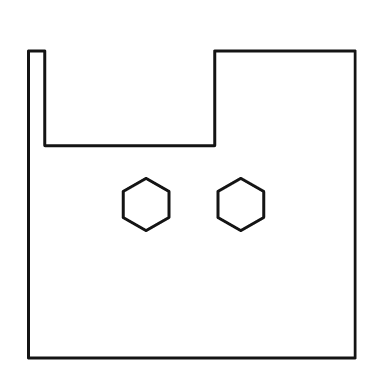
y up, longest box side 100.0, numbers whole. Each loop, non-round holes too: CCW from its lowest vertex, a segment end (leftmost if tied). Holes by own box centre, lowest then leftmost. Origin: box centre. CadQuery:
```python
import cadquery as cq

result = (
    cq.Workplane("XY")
    .moveTo(-50.0, -47.0)
    .lineTo(50.0, -47.0)
    .lineTo(50.0, 47.0)
    .lineTo(7.0, 47.0)
    .lineTo(7.0, 18.0)
    .lineTo(-45.0, 18.0)
    .lineTo(-45.0, 47.0)
    .lineTo(-50.0, 47.0)
    .close()
    .moveTo(-14.0, -8.0)
    .lineTo(-7.0, -4.0)
    .lineTo(-7.0, 4.0)
    .lineTo(-14.0, 8.0)
    .lineTo(-21.0, 4.0)
    .lineTo(-21.0, -4.0)
    .close()
    .moveTo(15.0, -8.0)
    .lineTo(22.0, -4.0)
    .lineTo(22.0, 4.0)
    .lineTo(15.0, 8.0)
    .lineTo(8.0, 4.0)
    .lineTo(8.0, -4.0)
    .close()
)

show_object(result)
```